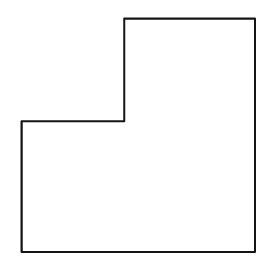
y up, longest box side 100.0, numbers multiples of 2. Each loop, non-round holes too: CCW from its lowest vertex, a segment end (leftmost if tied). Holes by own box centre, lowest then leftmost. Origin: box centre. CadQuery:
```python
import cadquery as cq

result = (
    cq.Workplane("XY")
    .moveTo(-50.0, -50.0)
    .lineTo(50.0, -50.0)
    .lineTo(50.0, 50.0)
    .lineTo(-6.0, 50.0)
    .lineTo(-6.0, 6.0)
    .lineTo(-50.0, 6.0)
    .close()
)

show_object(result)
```